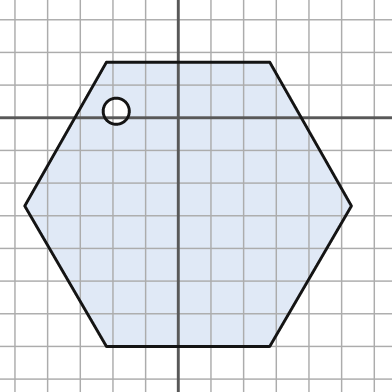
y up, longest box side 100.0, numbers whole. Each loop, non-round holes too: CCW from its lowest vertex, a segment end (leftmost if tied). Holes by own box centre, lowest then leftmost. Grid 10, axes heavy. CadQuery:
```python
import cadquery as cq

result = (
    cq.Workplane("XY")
    .moveTo(-22.0, -70.0)
    .lineTo(28.0, -70.0)
    .lineTo(53.0, -27.0)
    .lineTo(28.0, 17.0)
    .lineTo(-22.0, 17.0)
    .lineTo(-47.0, -27.0)
    .close()
    .moveTo(-19.0, 2.0)
    .circle(4.0)
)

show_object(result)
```